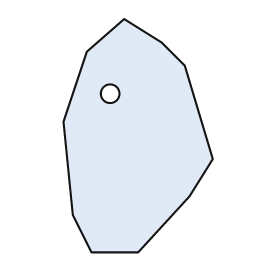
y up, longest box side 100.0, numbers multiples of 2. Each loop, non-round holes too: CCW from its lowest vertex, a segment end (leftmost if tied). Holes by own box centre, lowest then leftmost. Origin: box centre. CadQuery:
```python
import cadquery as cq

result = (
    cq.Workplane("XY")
    .moveTo(-20.0, -50.0)
    .lineTo(0.0, -50.0)
    .lineTo(22.0, -26.0)
    .lineTo(32.0, -10.0)
    .lineTo(20.0, 30.0)
    .lineTo(10.0, 40.0)
    .lineTo(-6.0, 50.0)
    .lineTo(-22.0, 36.0)
    .lineTo(-32.0, 6.0)
    .lineTo(-28.0, -34.0)
    .close()
    .moveTo(-12.0, 18.0)
    .circle(4.0)
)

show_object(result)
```